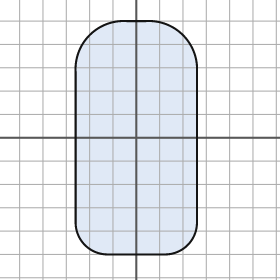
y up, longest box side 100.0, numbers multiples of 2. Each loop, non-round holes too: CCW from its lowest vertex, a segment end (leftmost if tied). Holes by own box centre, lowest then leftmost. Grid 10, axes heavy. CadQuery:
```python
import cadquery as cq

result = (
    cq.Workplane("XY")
    .moveTo(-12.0, -50.0)
    .lineTo(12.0, -50.0)
    .threePointArc((22.0, -46.0), (26.0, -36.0))
    .lineTo(26.0, 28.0)
    .threePointArc((20.0, 44.0), (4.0, 50.0))
    .lineTo(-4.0, 50.0)
    .threePointArc((-20.0, 44.0), (-26.0, 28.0))
    .lineTo(-26.0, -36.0)
    .threePointArc((-22.0, -46.0), (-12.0, -50.0))
    .close()
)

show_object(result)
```